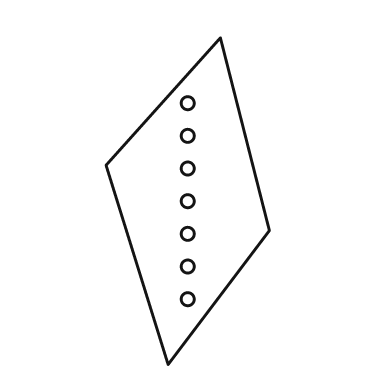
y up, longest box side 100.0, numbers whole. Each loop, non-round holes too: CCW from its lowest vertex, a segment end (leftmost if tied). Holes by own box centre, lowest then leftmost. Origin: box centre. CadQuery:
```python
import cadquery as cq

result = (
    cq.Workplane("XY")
    .moveTo(-6.0, -50.0)
    .lineTo(25.0, -9.0)
    .lineTo(10.0, 50.0)
    .lineTo(-25.0, 11.0)
    .close()
    .moveTo(0.0, -30.0)
    .circle(2.0)
    .moveTo(0.0, -20.0)
    .circle(2.0)
    .moveTo(0.0, -10.0)
    .circle(2.0)
    .moveTo(0.0, 0.0)
    .circle(2.0)
    .moveTo(0.0, 10.0)
    .circle(2.0)
    .moveTo(0.0, 20.0)
    .circle(2.0)
    .moveTo(0.0, 30.0)
    .circle(2.0)
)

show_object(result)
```